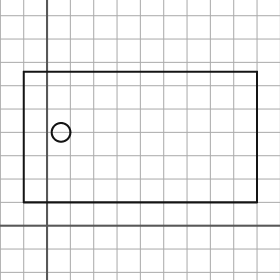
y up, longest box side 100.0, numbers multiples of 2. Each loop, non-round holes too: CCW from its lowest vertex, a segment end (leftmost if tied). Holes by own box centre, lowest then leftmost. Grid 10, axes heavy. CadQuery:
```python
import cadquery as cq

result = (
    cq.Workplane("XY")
    .moveTo(-10.0, 10.0)
    .lineTo(90.0, 10.0)
    .lineTo(90.0, 66.0)
    .lineTo(-10.0, 66.0)
    .close()
    .moveTo(6.0, 40.0)
    .circle(4.0)
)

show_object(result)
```